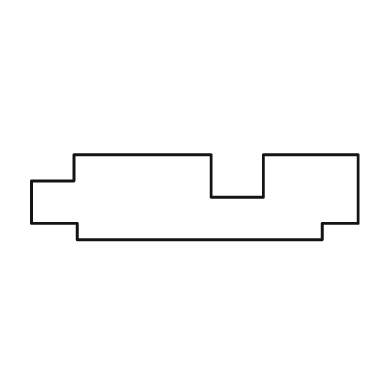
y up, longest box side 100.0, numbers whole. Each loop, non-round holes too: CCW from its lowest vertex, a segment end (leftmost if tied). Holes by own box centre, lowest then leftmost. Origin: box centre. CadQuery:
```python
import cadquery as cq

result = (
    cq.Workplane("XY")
    .moveTo(-36.0, -13.0)
    .lineTo(39.0, -13.0)
    .lineTo(39.0, -8.0)
    .lineTo(50.0, -8.0)
    .lineTo(50.0, 13.0)
    .lineTo(21.0, 13.0)
    .lineTo(21.0, 0.0)
    .lineTo(5.0, 0.0)
    .lineTo(5.0, 13.0)
    .lineTo(-37.0, 13.0)
    .lineTo(-37.0, 5.0)
    .lineTo(-50.0, 5.0)
    .lineTo(-50.0, -8.0)
    .lineTo(-36.0, -8.0)
    .close()
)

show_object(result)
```